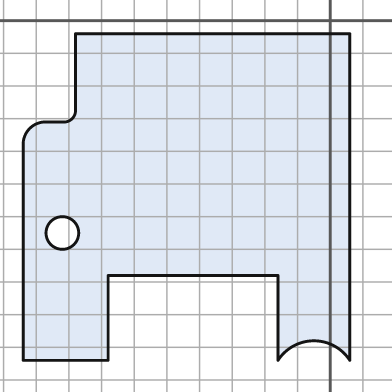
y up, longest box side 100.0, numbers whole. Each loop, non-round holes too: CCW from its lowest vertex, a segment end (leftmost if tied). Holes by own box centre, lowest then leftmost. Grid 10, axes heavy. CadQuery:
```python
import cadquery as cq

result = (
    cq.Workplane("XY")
    .moveTo(-94.0, -104.0)
    .lineTo(-68.0, -104.0)
    .lineTo(-68.0, -78.0)
    .lineTo(-16.0, -78.0)
    .lineTo(-16.0, -104.0)
    .threePointArc((-5.0, -98.0), (6.0, -104.0))
    .lineTo(6.0, -4.0)
    .lineTo(-78.0, -4.0)
    .lineTo(-78.0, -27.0)
    .threePointArc((-79.0, -30.0), (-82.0, -31.0))
    .lineTo(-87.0, -31.0)
    .threePointArc((-92.0, -33.0), (-94.0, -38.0))
    .close()
    .moveTo(-82.0, -65.0)
    .circle(5.0)
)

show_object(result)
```